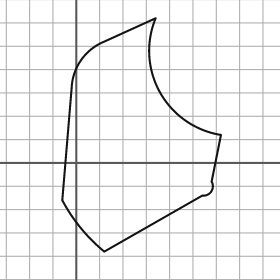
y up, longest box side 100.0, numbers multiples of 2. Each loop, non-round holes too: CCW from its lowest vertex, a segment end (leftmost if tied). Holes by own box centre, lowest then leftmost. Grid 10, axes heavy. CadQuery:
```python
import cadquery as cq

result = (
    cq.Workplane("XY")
    .moveTo(12.0, -38.0)
    .lineTo(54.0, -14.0)
    .threePointArc((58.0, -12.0), (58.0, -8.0))
    .lineTo(62.0, 12.0)
    .threePointArc((36.0, 30.0), (34.0, 62.0))
    .lineTo(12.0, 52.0)
    .threePointArc((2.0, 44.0), (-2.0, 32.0))
    .lineTo(-6.0, -16.0)
    .threePointArc((2.0, -28.0), (12.0, -38.0))
    .close()
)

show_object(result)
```